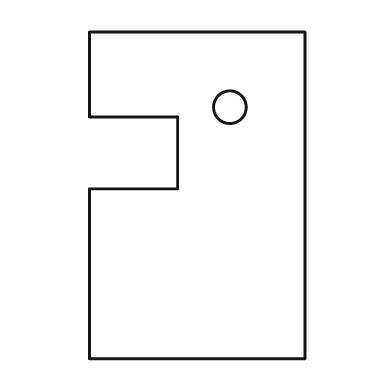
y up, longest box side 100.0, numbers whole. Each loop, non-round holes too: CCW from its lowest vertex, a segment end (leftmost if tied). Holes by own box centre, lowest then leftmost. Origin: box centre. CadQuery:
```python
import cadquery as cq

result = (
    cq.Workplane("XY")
    .moveTo(-33.0, -50.0)
    .lineTo(33.0, -50.0)
    .lineTo(33.0, 50.0)
    .lineTo(-33.0, 50.0)
    .lineTo(-33.0, 24.0)
    .lineTo(-6.0, 24.0)
    .lineTo(-6.0, 2.0)
    .lineTo(-33.0, 2.0)
    .close()
    .moveTo(10.0, 27.0)
    .circle(5.0)
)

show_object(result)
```